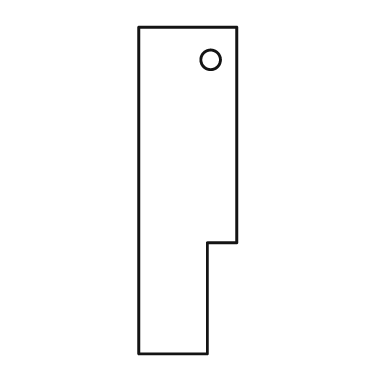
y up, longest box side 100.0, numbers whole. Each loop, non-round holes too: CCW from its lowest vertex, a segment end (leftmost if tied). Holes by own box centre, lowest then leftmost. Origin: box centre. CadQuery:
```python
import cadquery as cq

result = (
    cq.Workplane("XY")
    .moveTo(-15.0, -50.0)
    .lineTo(6.0, -50.0)
    .lineTo(6.0, -16.0)
    .lineTo(15.0, -16.0)
    .lineTo(15.0, 50.0)
    .lineTo(-15.0, 50.0)
    .close()
    .moveTo(7.0, 40.0)
    .circle(3.0)
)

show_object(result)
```